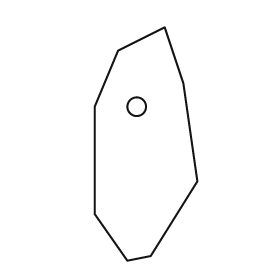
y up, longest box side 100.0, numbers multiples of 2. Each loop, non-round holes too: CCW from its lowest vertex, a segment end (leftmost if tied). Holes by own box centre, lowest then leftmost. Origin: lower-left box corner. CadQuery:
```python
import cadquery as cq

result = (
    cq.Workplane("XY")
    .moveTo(14.0, 0.0)
    .lineTo(24.0, 2.0)
    .lineTo(44.0, 34.0)
    .lineTo(38.0, 76.0)
    .lineTo(30.0, 100.0)
    .lineTo(10.0, 90.0)
    .lineTo(0.0, 66.0)
    .lineTo(0.0, 20.0)
    .close()
    .moveTo(18.0, 66.0)
    .circle(4.0)
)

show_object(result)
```